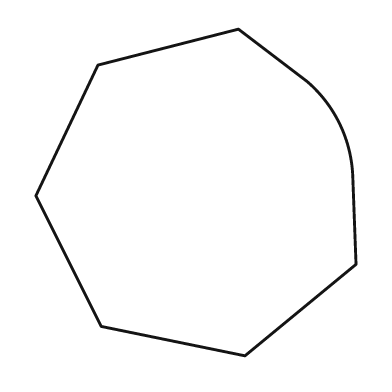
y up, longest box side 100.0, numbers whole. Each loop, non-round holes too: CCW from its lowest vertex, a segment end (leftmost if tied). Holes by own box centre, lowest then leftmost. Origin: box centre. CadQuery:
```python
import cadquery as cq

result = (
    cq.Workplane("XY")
    .moveTo(15.0, -50.0)
    .lineTo(49.0, -22.0)
    .lineTo(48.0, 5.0)
    .threePointArc((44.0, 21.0), (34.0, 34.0))
    .lineTo(13.0, 50.0)
    .lineTo(-30.0, 39.0)
    .lineTo(-49.0, -1.0)
    .lineTo(-29.0, -41.0)
    .close()
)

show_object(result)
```